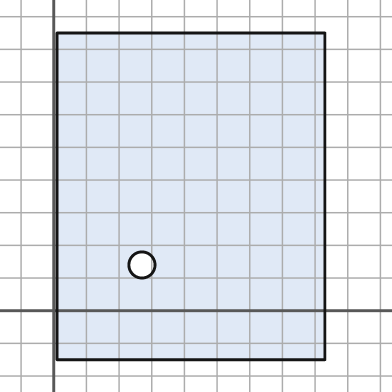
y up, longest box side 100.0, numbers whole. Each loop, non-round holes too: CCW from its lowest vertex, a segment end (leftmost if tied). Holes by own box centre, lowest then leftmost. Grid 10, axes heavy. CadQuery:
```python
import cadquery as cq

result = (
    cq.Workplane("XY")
    .moveTo(1.0, -15.0)
    .lineTo(83.0, -15.0)
    .lineTo(83.0, 85.0)
    .lineTo(1.0, 85.0)
    .close()
    .moveTo(27.0, 14.0)
    .circle(4.0)
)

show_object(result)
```